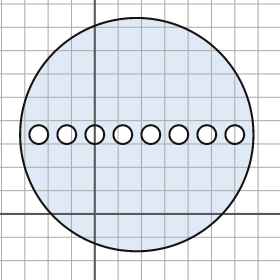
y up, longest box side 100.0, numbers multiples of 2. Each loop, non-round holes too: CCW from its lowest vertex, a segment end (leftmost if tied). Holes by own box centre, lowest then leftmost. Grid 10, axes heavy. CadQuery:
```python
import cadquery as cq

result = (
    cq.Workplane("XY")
    .moveTo(18.0, 34.0)
    .circle(50.0)
    .moveTo(-24.0, 34.0)
    .circle(4.0)
    .moveTo(-12.0, 34.0)
    .circle(4.0)
    .moveTo(0.0, 34.0)
    .circle(4.0)
    .moveTo(12.0, 34.0)
    .circle(4.0)
    .moveTo(24.0, 34.0)
    .circle(4.0)
    .moveTo(36.0, 34.0)
    .circle(4.0)
    .moveTo(48.0, 34.0)
    .circle(4.0)
    .moveTo(60.0, 34.0)
    .circle(4.0)
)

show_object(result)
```